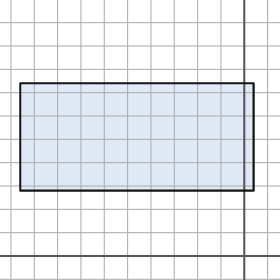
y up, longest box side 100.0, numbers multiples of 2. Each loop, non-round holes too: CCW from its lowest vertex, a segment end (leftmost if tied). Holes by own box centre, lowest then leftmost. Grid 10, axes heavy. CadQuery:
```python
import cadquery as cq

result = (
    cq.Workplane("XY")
    .moveTo(-96.0, 28.0)
    .lineTo(4.0, 28.0)
    .lineTo(4.0, 74.0)
    .lineTo(-96.0, 74.0)
    .close()
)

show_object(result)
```